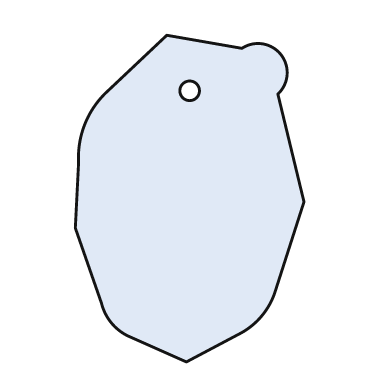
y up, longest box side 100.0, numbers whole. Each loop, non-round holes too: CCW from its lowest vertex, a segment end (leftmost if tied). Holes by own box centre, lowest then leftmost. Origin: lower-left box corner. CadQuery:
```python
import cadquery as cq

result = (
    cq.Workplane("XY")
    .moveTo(34.0, 0.0)
    .lineTo(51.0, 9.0)
    .threePointArc((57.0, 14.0), (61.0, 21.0))
    .lineTo(70.0, 49.0)
    .lineTo(62.0, 82.0)
    .threePointArc((63.0, 94.0), (51.0, 96.0))
    .lineTo(28.0, 100.0)
    .lineTo(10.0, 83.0)
    .threePointArc((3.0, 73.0), (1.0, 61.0))
    .lineTo(0.0, 41.0)
    .lineTo(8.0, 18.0)
    .threePointArc((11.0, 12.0), (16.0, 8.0))
    .close()
    .moveTo(35.0, 83.0)
    .circle(3.0)
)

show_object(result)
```